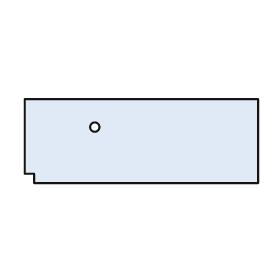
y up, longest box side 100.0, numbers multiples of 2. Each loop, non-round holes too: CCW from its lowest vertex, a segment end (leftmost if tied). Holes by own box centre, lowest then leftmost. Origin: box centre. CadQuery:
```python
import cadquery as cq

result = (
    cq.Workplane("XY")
    .moveTo(-46.0, -18.0)
    .lineTo(50.0, -18.0)
    .lineTo(50.0, 18.0)
    .lineTo(-50.0, 18.0)
    .lineTo(-50.0, -14.0)
    .lineTo(-46.0, -14.0)
    .close()
    .moveTo(-20.0, 6.0)
    .circle(2.0)
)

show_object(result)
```